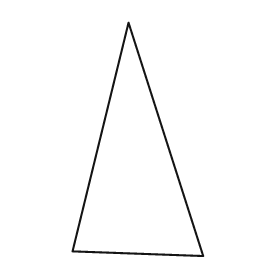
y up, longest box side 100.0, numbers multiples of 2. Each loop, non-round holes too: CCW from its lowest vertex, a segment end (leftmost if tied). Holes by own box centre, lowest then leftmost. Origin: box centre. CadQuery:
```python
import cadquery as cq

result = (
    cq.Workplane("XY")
    .moveTo(28.0, -50.0)
    .lineTo(-4.0, 50.0)
    .lineTo(-28.0, -48.0)
    .close()
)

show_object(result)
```